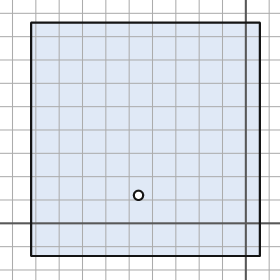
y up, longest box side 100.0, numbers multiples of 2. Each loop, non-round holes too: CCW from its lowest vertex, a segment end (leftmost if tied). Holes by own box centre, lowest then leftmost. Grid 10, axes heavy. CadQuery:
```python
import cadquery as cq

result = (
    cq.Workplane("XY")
    .moveTo(-92.0, -14.0)
    .lineTo(6.0, -14.0)
    .lineTo(6.0, 86.0)
    .lineTo(-92.0, 86.0)
    .close()
    .moveTo(-46.0, 12.0)
    .circle(2.0)
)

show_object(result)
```